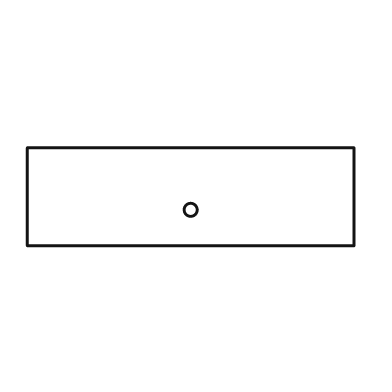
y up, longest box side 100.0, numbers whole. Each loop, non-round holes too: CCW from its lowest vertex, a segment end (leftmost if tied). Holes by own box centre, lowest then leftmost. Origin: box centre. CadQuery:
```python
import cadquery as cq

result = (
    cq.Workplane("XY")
    .moveTo(-50.0, -15.0)
    .lineTo(50.0, -15.0)
    .lineTo(50.0, 15.0)
    .lineTo(-50.0, 15.0)
    .close()
    .moveTo(0.0, -4.0)
    .circle(2.0)
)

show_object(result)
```